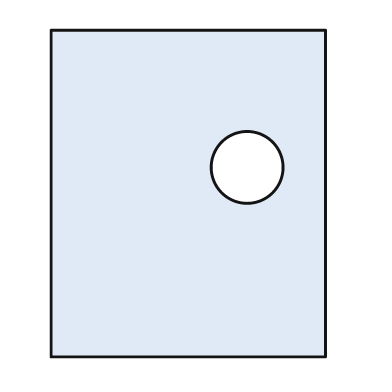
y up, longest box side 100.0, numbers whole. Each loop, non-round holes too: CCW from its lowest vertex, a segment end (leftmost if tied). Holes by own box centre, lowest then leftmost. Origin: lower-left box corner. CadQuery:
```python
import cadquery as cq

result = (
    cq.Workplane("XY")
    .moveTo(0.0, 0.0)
    .lineTo(84.0, 0.0)
    .lineTo(84.0, 100.0)
    .lineTo(0.0, 100.0)
    .close()
    .moveTo(60.0, 58.0)
    .circle(11.0)
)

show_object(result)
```